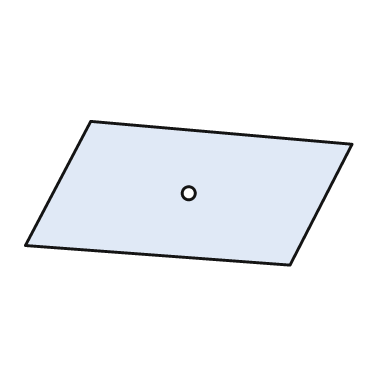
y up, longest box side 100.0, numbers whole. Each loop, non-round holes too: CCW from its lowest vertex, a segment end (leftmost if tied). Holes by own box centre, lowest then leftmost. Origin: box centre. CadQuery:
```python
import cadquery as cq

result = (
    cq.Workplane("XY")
    .moveTo(31.0, -22.0)
    .lineTo(50.0, 15.0)
    .lineTo(-30.0, 22.0)
    .lineTo(-50.0, -16.0)
    .close()
    .moveTo(0.0, 0.0)
    .circle(2.0)
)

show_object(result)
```